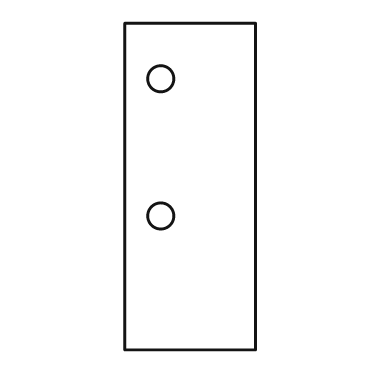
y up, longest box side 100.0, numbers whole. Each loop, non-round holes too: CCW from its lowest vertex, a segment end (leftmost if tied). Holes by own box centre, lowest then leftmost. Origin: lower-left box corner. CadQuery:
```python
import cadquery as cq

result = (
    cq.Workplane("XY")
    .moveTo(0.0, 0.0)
    .lineTo(40.0, 0.0)
    .lineTo(40.0, 100.0)
    .lineTo(0.0, 100.0)
    .close()
    .moveTo(11.0, 41.0)
    .circle(4.0)
    .moveTo(11.0, 83.0)
    .circle(4.0)
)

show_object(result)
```